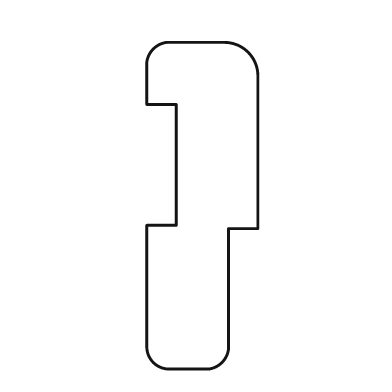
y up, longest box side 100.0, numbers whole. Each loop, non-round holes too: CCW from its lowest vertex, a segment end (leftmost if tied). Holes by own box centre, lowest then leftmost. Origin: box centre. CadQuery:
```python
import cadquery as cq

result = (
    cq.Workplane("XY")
    .moveTo(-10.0, -50.0)
    .lineTo(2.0, -50.0)
    .threePointArc((6.0, -48.0), (8.0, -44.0))
    .lineTo(8.0, -7.0)
    .lineTo(17.0, -7.0)
    .lineTo(17.0, 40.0)
    .threePointArc((14.0, 47.0), (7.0, 50.0))
    .lineTo(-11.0, 50.0)
    .threePointArc((-15.0, 48.0), (-17.0, 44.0))
    .lineTo(-17.0, 31.0)
    .lineTo(-8.0, 31.0)
    .lineTo(-8.0, -6.0)
    .lineTo(-17.0, -6.0)
    .lineTo(-17.0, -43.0)
    .threePointArc((-15.0, -48.0), (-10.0, -50.0))
    .close()
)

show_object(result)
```